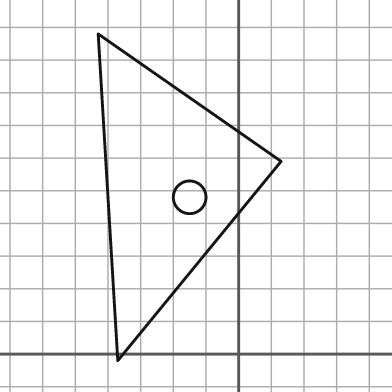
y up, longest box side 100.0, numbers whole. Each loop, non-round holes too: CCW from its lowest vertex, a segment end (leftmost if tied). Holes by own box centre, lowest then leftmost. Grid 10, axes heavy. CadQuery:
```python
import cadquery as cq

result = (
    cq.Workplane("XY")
    .moveTo(-37.0, -2.0)
    .lineTo(13.0, 59.0)
    .lineTo(-43.0, 98.0)
    .close()
    .moveTo(-15.0, 48.0)
    .circle(5.0)
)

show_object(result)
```